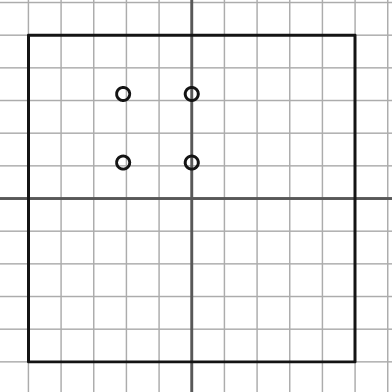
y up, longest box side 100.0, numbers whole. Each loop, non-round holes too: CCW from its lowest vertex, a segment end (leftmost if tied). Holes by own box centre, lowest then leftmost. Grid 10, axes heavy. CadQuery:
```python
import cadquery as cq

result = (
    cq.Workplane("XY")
    .moveTo(-50.0, -50.0)
    .lineTo(50.0, -50.0)
    .lineTo(50.0, 50.0)
    .lineTo(-50.0, 50.0)
    .close()
    .moveTo(-21.0, 11.0)
    .circle(2.0)
    .moveTo(0.0, 11.0)
    .circle(2.0)
    .moveTo(-21.0, 32.0)
    .circle(2.0)
    .moveTo(0.0, 32.0)
    .circle(2.0)
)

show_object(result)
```